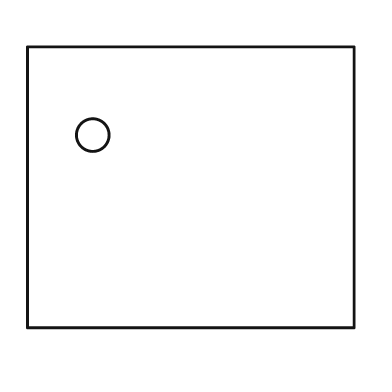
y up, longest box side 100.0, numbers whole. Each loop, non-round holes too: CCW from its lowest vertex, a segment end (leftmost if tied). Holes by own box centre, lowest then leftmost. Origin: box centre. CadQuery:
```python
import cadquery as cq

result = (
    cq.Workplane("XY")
    .moveTo(-50.0, -43.0)
    .lineTo(50.0, -43.0)
    .lineTo(50.0, 43.0)
    .lineTo(-50.0, 43.0)
    .close()
    .moveTo(-30.0, 16.0)
    .circle(5.0)
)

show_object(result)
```